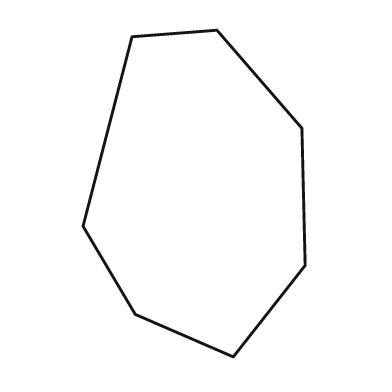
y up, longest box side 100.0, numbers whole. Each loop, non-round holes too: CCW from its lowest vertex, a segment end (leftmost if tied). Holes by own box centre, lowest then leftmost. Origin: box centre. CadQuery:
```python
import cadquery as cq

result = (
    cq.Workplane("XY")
    .moveTo(12.0, -50.0)
    .lineTo(34.0, -22.0)
    .lineTo(33.0, 20.0)
    .lineTo(7.0, 50.0)
    .lineTo(-19.0, 48.0)
    .lineTo(-34.0, -10.0)
    .lineTo(-18.0, -37.0)
    .close()
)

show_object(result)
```